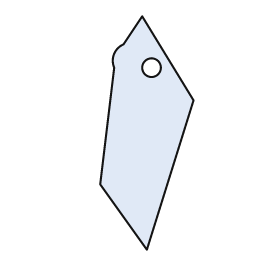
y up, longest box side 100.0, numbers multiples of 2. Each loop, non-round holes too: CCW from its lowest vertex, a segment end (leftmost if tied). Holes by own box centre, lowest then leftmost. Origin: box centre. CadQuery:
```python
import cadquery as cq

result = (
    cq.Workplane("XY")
    .moveTo(0.0, -50.0)
    .lineTo(20.0, 14.0)
    .lineTo(-2.0, 50.0)
    .lineTo(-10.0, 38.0)
    .threePointArc((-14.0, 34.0), (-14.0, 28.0))
    .lineTo(-20.0, -22.0)
    .close()
    .moveTo(2.0, 28.0)
    .circle(4.0)
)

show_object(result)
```